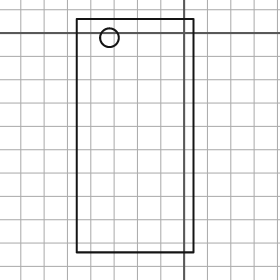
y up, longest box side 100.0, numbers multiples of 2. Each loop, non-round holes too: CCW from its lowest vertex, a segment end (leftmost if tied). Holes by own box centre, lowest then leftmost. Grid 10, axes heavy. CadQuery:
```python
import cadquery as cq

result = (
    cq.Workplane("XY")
    .moveTo(-46.0, -94.0)
    .lineTo(4.0, -94.0)
    .lineTo(4.0, 6.0)
    .lineTo(-46.0, 6.0)
    .close()
    .moveTo(-32.0, -2.0)
    .circle(4.0)
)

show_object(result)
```